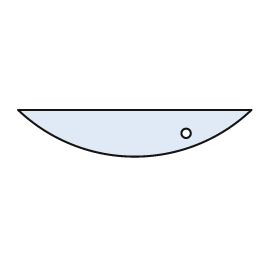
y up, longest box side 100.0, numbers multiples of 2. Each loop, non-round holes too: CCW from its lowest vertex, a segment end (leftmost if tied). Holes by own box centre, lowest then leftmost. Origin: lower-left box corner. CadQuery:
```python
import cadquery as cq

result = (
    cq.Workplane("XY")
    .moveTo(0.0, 20.0)
    .threePointArc((50.0, 0.0), (100.0, 20.0))
    .close()
    .moveTo(72.0, 10.0)
    .circle(2.0)
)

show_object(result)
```